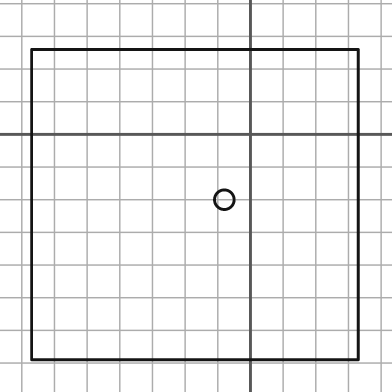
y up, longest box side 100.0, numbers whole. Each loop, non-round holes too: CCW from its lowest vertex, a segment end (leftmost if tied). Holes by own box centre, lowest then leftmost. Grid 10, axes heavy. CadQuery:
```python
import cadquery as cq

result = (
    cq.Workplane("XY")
    .moveTo(-67.0, -69.0)
    .lineTo(33.0, -69.0)
    .lineTo(33.0, 26.0)
    .lineTo(-67.0, 26.0)
    .close()
    .moveTo(-8.0, -20.0)
    .circle(3.0)
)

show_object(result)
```